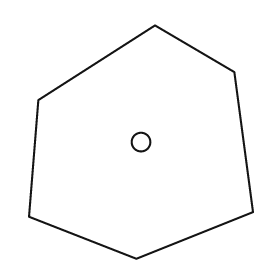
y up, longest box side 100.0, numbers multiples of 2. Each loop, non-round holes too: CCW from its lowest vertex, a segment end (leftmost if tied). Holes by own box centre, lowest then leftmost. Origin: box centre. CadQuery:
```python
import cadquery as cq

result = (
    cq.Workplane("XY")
    .moveTo(-2.0, -50.0)
    .lineTo(48.0, -30.0)
    .lineTo(40.0, 30.0)
    .lineTo(6.0, 50.0)
    .lineTo(-44.0, 18.0)
    .lineTo(-48.0, -32.0)
    .close()
    .moveTo(0.0, 0.0)
    .circle(4.0)
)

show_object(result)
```